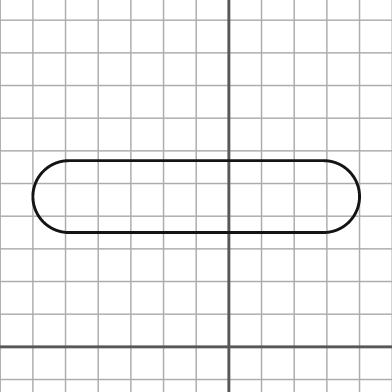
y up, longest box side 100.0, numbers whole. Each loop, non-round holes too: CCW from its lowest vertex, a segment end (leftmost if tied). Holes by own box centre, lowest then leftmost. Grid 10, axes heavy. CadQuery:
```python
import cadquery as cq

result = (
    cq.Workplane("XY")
    .moveTo(-49.0, 35.0)
    .lineTo(29.0, 35.0)
    .threePointArc((40.0, 46.0), (29.0, 57.0))
    .lineTo(-49.0, 57.0)
    .threePointArc((-60.0, 46.0), (-49.0, 35.0))
    .close()
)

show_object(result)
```